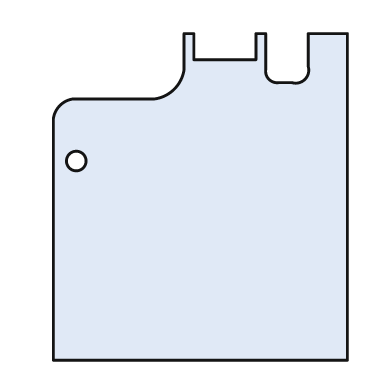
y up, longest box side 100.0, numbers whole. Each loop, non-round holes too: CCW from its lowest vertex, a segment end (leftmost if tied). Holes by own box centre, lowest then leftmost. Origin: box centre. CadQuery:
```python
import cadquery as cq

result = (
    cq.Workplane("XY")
    .moveTo(-45.0, -50.0)
    .lineTo(45.0, -50.0)
    .lineTo(45.0, 50.0)
    .lineTo(33.0, 50.0)
    .lineTo(33.0, 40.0)
    .threePointArc((32.0, 36.0), (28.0, 35.0))
    .lineTo(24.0, 35.0)
    .threePointArc((21.0, 36.0), (20.0, 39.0))
    .lineTo(20.0, 50.0)
    .lineTo(17.0, 50.0)
    .lineTo(17.0, 42.0)
    .lineTo(-2.0, 42.0)
    .lineTo(-2.0, 50.0)
    .lineTo(-5.0, 50.0)
    .lineTo(-5.0, 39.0)
    .threePointArc((-8.0, 33.0), (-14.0, 30.0))
    .lineTo(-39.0, 30.0)
    .threePointArc((-43.0, 28.0), (-45.0, 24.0))
    .close()
    .moveTo(-38.0, 11.0)
    .circle(3.0)
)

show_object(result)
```